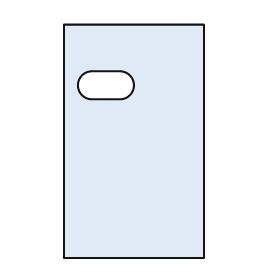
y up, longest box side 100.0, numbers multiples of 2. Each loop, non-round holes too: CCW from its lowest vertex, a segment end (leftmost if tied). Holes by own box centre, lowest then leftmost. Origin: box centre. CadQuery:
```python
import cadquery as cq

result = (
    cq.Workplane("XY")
    .moveTo(-30.0, -50.0)
    .lineTo(30.0, -50.0)
    .lineTo(30.0, 50.0)
    .lineTo(-30.0, 50.0)
    .close()
    .moveTo(-18.0, 18.0)
    .lineTo(-6.0, 18.0)
    .threePointArc((0.0, 24.0), (-6.0, 30.0))
    .lineTo(-18.0, 30.0)
    .threePointArc((-24.0, 24.0), (-18.0, 18.0))
    .close()
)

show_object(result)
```